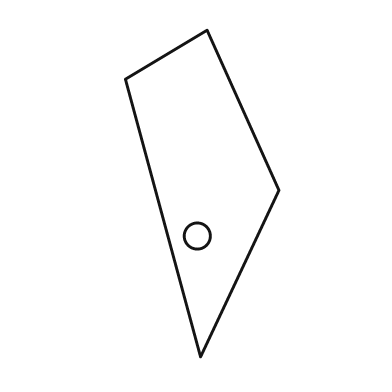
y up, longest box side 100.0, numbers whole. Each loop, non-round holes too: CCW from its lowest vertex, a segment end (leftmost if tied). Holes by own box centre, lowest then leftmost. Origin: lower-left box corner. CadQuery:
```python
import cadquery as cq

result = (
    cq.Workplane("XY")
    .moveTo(23.0, 0.0)
    .lineTo(47.0, 51.0)
    .lineTo(25.0, 100.0)
    .lineTo(0.0, 85.0)
    .close()
    .moveTo(22.0, 37.0)
    .circle(4.0)
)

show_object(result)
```